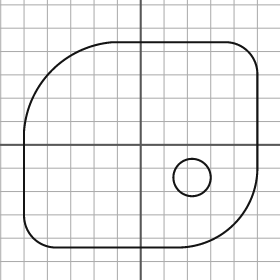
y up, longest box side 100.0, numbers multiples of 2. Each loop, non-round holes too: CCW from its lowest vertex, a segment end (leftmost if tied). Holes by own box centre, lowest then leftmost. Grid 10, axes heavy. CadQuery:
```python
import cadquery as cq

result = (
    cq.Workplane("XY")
    .moveTo(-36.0, -44.0)
    .lineTo(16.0, -44.0)
    .threePointArc((40.0, -34.0), (50.0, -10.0))
    .lineTo(50.0, 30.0)
    .threePointArc((46.0, 40.0), (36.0, 44.0))
    .lineTo(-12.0, 44.0)
    .threePointArc((-38.0, 32.0), (-50.0, 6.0))
    .lineTo(-50.0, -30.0)
    .threePointArc((-46.0, -40.0), (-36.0, -44.0))
    .close()
    .moveTo(22.0, -14.0)
    .circle(8.0)
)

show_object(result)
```